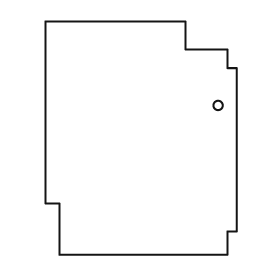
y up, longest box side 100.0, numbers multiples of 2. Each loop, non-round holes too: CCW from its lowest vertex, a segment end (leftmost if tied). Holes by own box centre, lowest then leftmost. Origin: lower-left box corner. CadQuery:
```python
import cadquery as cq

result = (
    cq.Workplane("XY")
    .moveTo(6.0, 0.0)
    .lineTo(78.0, 0.0)
    .lineTo(78.0, 10.0)
    .lineTo(82.0, 10.0)
    .lineTo(82.0, 80.0)
    .lineTo(78.0, 80.0)
    .lineTo(78.0, 88.0)
    .lineTo(60.0, 88.0)
    .lineTo(60.0, 100.0)
    .lineTo(0.0, 100.0)
    .lineTo(0.0, 22.0)
    .lineTo(6.0, 22.0)
    .close()
    .moveTo(74.0, 64.0)
    .circle(2.0)
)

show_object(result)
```